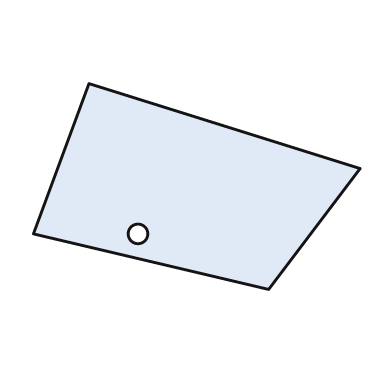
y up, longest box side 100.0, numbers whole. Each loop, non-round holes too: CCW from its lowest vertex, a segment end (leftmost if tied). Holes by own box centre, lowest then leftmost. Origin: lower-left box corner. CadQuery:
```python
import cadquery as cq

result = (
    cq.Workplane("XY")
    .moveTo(72.0, 0.0)
    .lineTo(100.0, 37.0)
    .lineTo(17.0, 63.0)
    .lineTo(0.0, 17.0)
    .close()
    .moveTo(32.0, 17.0)
    .circle(3.0)
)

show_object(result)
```